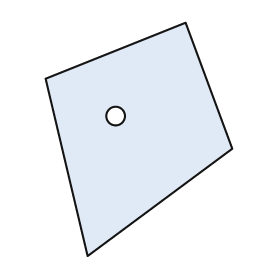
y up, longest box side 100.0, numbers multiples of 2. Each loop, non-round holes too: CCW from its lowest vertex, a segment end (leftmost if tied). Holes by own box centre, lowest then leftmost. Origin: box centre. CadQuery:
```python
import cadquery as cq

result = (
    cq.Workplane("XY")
    .moveTo(-22.0, -50.0)
    .lineTo(40.0, -4.0)
    .lineTo(20.0, 50.0)
    .lineTo(-40.0, 26.0)
    .close()
    .moveTo(-10.0, 10.0)
    .circle(4.0)
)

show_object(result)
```